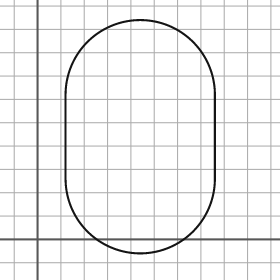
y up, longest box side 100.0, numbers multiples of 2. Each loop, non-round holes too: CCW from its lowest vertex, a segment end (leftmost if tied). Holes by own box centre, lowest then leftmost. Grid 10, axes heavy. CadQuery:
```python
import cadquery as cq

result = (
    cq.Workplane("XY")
    .moveTo(12.0, 26.0)
    .threePointArc((44.0, -6.0), (76.0, 26.0))
    .lineTo(76.0, 62.0)
    .threePointArc((44.0, 94.0), (12.0, 62.0))
    .close()
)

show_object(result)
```